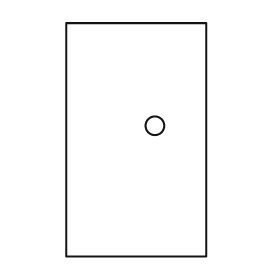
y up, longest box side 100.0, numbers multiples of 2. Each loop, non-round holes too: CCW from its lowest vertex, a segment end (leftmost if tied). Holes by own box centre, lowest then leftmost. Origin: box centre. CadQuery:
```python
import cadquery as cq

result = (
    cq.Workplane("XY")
    .moveTo(-30.0, -50.0)
    .lineTo(30.0, -50.0)
    .lineTo(30.0, 50.0)
    .lineTo(-30.0, 50.0)
    .close()
    .moveTo(8.0, 6.0)
    .circle(4.0)
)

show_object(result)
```